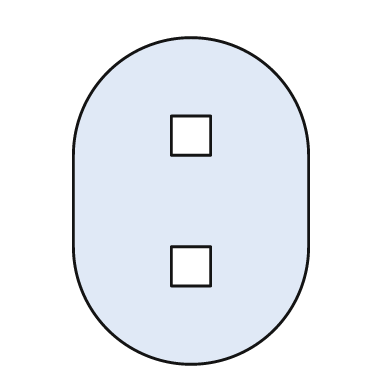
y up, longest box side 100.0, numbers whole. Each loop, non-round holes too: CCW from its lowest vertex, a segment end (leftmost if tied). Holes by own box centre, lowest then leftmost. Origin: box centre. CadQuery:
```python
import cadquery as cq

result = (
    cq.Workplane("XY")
    .moveTo(-36.0, -14.0)
    .threePointArc((0.0, -50.0), (36.0, -14.0))
    .lineTo(36.0, 14.0)
    .threePointArc((0.0, 50.0), (-36.0, 14.0))
    .close()
    .moveTo(-6.0, -26.0)
    .lineTo(6.0, -26.0)
    .lineTo(6.0, -14.0)
    .lineTo(-6.0, -14.0)
    .close()
    .moveTo(-6.0, 14.0)
    .lineTo(6.0, 14.0)
    .lineTo(6.0, 26.0)
    .lineTo(-6.0, 26.0)
    .close()
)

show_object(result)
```